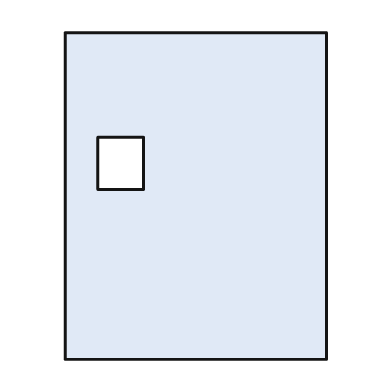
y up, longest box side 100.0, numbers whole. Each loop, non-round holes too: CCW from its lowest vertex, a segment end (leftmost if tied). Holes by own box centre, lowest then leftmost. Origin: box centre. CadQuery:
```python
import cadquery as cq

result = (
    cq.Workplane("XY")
    .moveTo(-40.0, -50.0)
    .lineTo(40.0, -50.0)
    .lineTo(40.0, 50.0)
    .lineTo(-40.0, 50.0)
    .close()
    .moveTo(-30.0, 2.0)
    .lineTo(-16.0, 2.0)
    .lineTo(-16.0, 18.0)
    .lineTo(-30.0, 18.0)
    .close()
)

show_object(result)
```